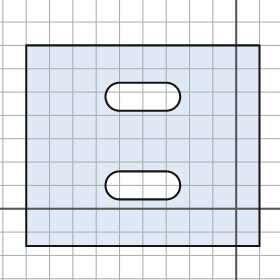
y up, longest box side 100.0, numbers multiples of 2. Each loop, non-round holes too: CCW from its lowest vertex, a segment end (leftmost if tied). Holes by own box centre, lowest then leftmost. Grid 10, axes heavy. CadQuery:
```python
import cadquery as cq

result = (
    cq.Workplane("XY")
    .moveTo(-90.0, -16.0)
    .lineTo(10.0, -16.0)
    .lineTo(10.0, 70.0)
    .lineTo(-90.0, 70.0)
    .close()
    .moveTo(-50.0, 4.0)
    .lineTo(-30.0, 4.0)
    .threePointArc((-24.0, 10.0), (-30.0, 16.0))
    .lineTo(-50.0, 16.0)
    .threePointArc((-56.0, 10.0), (-50.0, 4.0))
    .close()
    .moveTo(-50.0, 42.0)
    .lineTo(-30.0, 42.0)
    .threePointArc((-24.0, 48.0), (-30.0, 54.0))
    .lineTo(-50.0, 54.0)
    .threePointArc((-56.0, 48.0), (-50.0, 42.0))
    .close()
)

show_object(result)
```